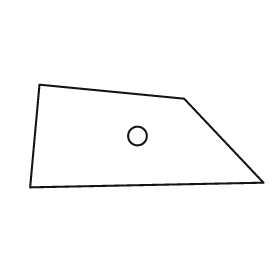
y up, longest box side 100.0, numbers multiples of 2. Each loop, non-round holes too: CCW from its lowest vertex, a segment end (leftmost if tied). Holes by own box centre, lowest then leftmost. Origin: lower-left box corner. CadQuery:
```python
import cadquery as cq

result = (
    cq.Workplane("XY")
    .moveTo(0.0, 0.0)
    .lineTo(100.0, 2.0)
    .lineTo(66.0, 38.0)
    .lineTo(4.0, 44.0)
    .close()
    .moveTo(46.0, 22.0)
    .circle(4.0)
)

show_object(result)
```